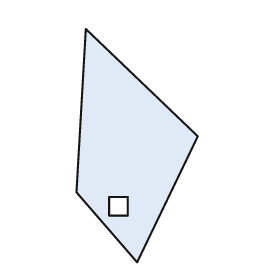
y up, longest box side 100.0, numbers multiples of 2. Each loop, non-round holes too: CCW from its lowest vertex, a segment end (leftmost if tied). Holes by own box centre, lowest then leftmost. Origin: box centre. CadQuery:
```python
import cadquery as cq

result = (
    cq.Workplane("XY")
    .moveTo(0.0, -50.0)
    .lineTo(26.0, 4.0)
    .lineTo(-22.0, 50.0)
    .lineTo(-26.0, -20.0)
    .close()
    .moveTo(-12.0, -30.0)
    .lineTo(-4.0, -30.0)
    .lineTo(-4.0, -22.0)
    .lineTo(-12.0, -22.0)
    .close()
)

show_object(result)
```